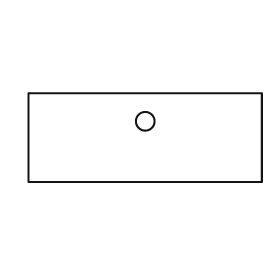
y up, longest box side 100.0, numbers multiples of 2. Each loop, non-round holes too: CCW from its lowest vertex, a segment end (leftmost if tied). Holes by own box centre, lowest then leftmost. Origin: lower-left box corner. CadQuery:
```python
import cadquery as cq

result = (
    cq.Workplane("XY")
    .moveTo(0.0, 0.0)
    .lineTo(100.0, 0.0)
    .lineTo(100.0, 38.0)
    .lineTo(0.0, 38.0)
    .close()
    .moveTo(50.0, 26.0)
    .circle(4.0)
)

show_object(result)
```